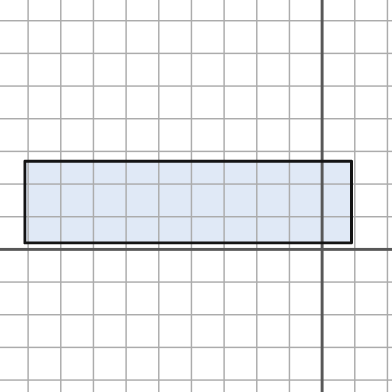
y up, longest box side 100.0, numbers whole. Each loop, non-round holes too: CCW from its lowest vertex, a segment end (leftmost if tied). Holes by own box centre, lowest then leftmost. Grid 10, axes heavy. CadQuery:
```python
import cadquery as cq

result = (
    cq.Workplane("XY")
    .moveTo(-91.0, 2.0)
    .lineTo(9.0, 2.0)
    .lineTo(9.0, 27.0)
    .lineTo(-91.0, 27.0)
    .close()
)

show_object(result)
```